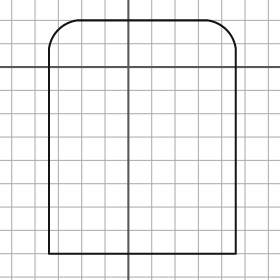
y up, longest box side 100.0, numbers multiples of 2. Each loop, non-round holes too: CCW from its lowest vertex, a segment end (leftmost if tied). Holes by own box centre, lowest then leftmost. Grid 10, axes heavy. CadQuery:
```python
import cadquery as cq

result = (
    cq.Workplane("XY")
    .moveTo(-34.0, -80.0)
    .lineTo(46.0, -80.0)
    .lineTo(46.0, 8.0)
    .threePointArc((42.0, 16.0), (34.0, 20.0))
    .lineTo(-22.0, 20.0)
    .threePointArc((-30.0, 16.0), (-34.0, 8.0))
    .close()
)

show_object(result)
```